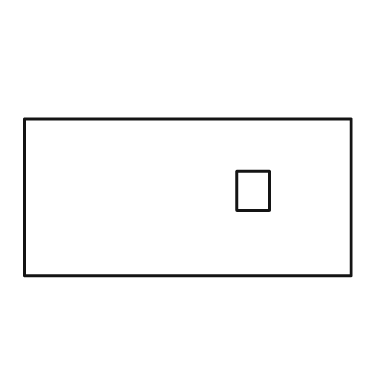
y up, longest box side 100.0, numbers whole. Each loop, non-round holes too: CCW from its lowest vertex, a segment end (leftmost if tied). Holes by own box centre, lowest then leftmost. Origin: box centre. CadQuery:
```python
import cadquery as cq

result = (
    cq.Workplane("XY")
    .moveTo(-50.0, -24.0)
    .lineTo(50.0, -24.0)
    .lineTo(50.0, 24.0)
    .lineTo(-50.0, 24.0)
    .close()
    .moveTo(15.0, -4.0)
    .lineTo(25.0, -4.0)
    .lineTo(25.0, 8.0)
    .lineTo(15.0, 8.0)
    .close()
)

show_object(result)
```